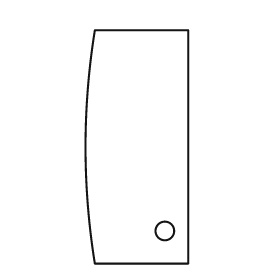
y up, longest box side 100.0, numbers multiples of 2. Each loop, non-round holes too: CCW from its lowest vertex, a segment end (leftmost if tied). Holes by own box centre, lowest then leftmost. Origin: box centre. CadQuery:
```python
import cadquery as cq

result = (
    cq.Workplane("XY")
    .moveTo(-18.0, -50.0)
    .lineTo(22.0, -50.0)
    .lineTo(22.0, 50.0)
    .lineTo(-18.0, 50.0)
    .threePointArc((-22.0, 0.0), (-18.0, -50.0))
    .close()
    .moveTo(12.0, -36.0)
    .circle(4.0)
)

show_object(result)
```